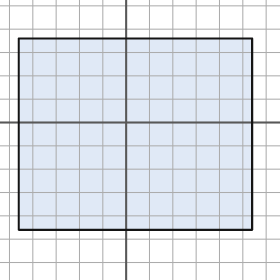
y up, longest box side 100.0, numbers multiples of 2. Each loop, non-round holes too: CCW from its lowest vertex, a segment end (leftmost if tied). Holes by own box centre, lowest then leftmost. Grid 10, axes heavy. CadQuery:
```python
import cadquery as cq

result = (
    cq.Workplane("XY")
    .moveTo(-46.0, -46.0)
    .lineTo(54.0, -46.0)
    .lineTo(54.0, 36.0)
    .lineTo(-46.0, 36.0)
    .close()
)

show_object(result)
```